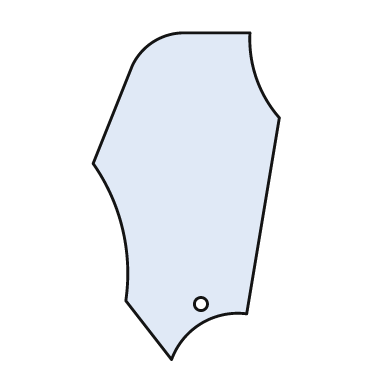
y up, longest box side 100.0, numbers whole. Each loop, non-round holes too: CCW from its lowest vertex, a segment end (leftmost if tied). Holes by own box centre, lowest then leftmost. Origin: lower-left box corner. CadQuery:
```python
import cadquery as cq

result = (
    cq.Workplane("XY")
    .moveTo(24.0, 0.0)
    .threePointArc((33.0, 11.0), (47.0, 14.0))
    .lineTo(57.0, 74.0)
    .threePointArc((50.0, 86.0), (48.0, 100.0))
    .lineTo(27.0, 100.0)
    .threePointArc((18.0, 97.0), (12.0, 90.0))
    .lineTo(0.0, 60.0)
    .threePointArc((9.0, 40.0), (10.0, 18.0))
    .close()
    .moveTo(33.0, 17.0)
    .circle(2.0)
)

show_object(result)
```